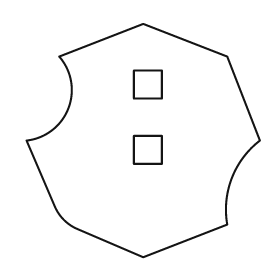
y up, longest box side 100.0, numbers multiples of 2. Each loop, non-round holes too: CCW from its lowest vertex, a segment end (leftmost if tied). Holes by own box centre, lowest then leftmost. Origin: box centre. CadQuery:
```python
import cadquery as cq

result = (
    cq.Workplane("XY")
    .moveTo(0.0, -50.0)
    .lineTo(36.0, -36.0)
    .threePointArc((38.0, -16.0), (50.0, 0.0))
    .lineTo(36.0, 36.0)
    .lineTo(0.0, 50.0)
    .lineTo(-36.0, 36.0)
    .threePointArc((-32.0, 14.0), (-50.0, 0.0))
    .lineTo(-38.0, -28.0)
    .threePointArc((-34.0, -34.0), (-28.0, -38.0))
    .close()
    .moveTo(-4.0, -10.0)
    .lineTo(8.0, -10.0)
    .lineTo(8.0, 2.0)
    .lineTo(-4.0, 2.0)
    .close()
    .moveTo(-4.0, 18.0)
    .lineTo(8.0, 18.0)
    .lineTo(8.0, 30.0)
    .lineTo(-4.0, 30.0)
    .close()
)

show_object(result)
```